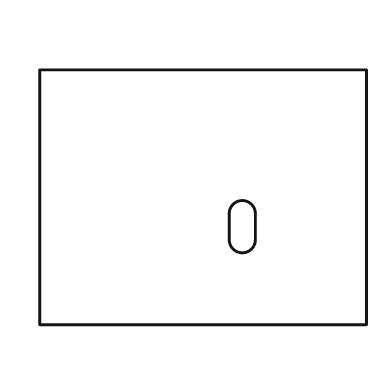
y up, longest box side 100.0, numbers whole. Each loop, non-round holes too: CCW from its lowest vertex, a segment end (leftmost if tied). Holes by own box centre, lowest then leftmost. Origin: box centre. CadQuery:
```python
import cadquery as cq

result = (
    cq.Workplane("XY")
    .moveTo(-50.0, -39.0)
    .lineTo(50.0, -39.0)
    .lineTo(50.0, 39.0)
    .lineTo(-50.0, 39.0)
    .close()
    .moveTo(8.0, -13.0)
    .threePointArc((12.0, -17.0), (16.0, -13.0))
    .lineTo(16.0, -5.0)
    .threePointArc((12.0, -1.0), (8.0, -5.0))
    .close()
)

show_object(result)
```